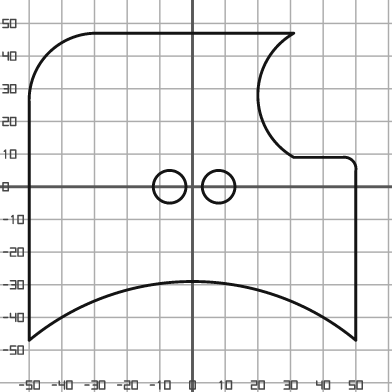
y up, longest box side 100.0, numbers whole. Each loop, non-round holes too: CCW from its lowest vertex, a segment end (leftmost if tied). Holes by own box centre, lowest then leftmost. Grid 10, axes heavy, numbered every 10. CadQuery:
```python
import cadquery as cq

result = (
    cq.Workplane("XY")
    .moveTo(-50.0, -47.0)
    .threePointArc((0.0, -29.0), (50.0, -47.0))
    .lineTo(50.0, 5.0)
    .threePointArc((49.0, 8.0), (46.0, 9.0))
    .lineTo(31.0, 9.0)
    .threePointArc((20.0, 28.0), (31.0, 47.0))
    .lineTo(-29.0, 47.0)
    .threePointArc((-44.0, 41.0), (-50.0, 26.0))
    .close()
    .moveTo(-7.0, 0.0)
    .circle(5.0)
    .moveTo(8.0, 0.0)
    .circle(5.0)
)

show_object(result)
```